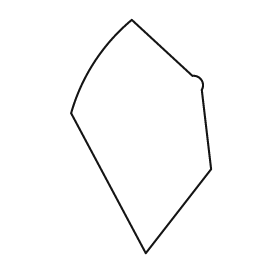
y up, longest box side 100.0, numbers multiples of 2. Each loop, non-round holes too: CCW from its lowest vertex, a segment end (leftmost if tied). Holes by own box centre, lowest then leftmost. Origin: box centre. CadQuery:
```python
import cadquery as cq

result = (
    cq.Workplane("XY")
    .moveTo(2.0, -50.0)
    .lineTo(30.0, -14.0)
    .lineTo(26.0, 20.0)
    .threePointArc((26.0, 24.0), (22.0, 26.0))
    .lineTo(-4.0, 50.0)
    .threePointArc((-20.0, 32.0), (-30.0, 10.0))
    .close()
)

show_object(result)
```